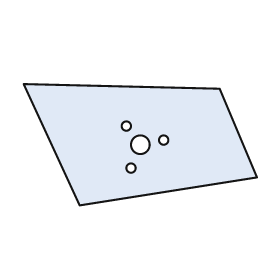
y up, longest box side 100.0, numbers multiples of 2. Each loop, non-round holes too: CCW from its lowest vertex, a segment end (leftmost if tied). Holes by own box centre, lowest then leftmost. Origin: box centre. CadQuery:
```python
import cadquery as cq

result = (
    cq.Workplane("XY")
    .moveTo(-26.0, -26.0)
    .lineTo(50.0, -14.0)
    .lineTo(34.0, 24.0)
    .lineTo(-50.0, 26.0)
    .close()
    .moveTo(-4.0, -10.0)
    .circle(2.0)
    .moveTo(0.0, 0.0)
    .circle(4.0)
    .moveTo(10.0, 2.0)
    .circle(2.0)
    .moveTo(-6.0, 8.0)
    .circle(2.0)
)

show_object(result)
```